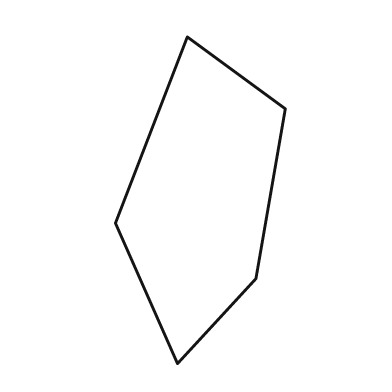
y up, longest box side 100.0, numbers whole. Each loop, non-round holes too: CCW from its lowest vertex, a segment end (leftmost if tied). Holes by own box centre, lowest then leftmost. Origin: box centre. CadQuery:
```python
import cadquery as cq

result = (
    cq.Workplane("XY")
    .moveTo(-7.0, -50.0)
    .lineTo(17.0, -24.0)
    .lineTo(26.0, 28.0)
    .lineTo(-4.0, 50.0)
    .lineTo(-26.0, -7.0)
    .close()
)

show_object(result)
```